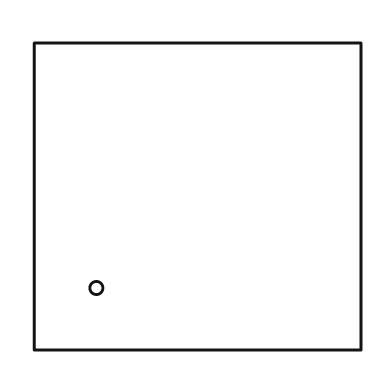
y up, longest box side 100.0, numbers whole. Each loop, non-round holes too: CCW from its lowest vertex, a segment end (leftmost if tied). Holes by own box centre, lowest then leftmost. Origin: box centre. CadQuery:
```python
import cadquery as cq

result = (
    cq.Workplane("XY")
    .moveTo(-50.0, -47.0)
    .lineTo(50.0, -47.0)
    .lineTo(50.0, 47.0)
    .lineTo(-50.0, 47.0)
    .close()
    .moveTo(-31.0, -28.0)
    .circle(2.0)
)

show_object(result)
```